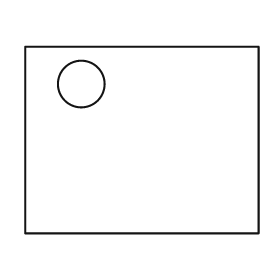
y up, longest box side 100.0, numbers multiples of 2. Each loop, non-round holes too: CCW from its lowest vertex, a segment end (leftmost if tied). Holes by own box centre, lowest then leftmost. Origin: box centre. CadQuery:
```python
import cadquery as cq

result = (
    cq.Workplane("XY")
    .moveTo(-50.0, -40.0)
    .lineTo(50.0, -40.0)
    .lineTo(50.0, 40.0)
    .lineTo(-50.0, 40.0)
    .close()
    .moveTo(-26.0, 24.0)
    .circle(10.0)
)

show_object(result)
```